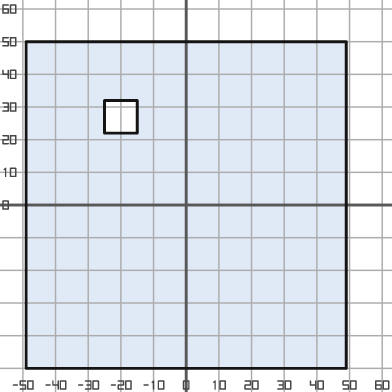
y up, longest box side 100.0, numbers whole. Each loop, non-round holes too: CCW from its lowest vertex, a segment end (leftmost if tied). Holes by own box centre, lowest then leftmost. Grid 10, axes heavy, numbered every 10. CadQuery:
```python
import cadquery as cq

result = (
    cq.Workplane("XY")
    .moveTo(-49.0, -50.0)
    .lineTo(49.0, -50.0)
    .lineTo(49.0, 50.0)
    .lineTo(-49.0, 50.0)
    .close()
    .moveTo(-25.0, 22.0)
    .lineTo(-15.0, 22.0)
    .lineTo(-15.0, 32.0)
    .lineTo(-25.0, 32.0)
    .close()
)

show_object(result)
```